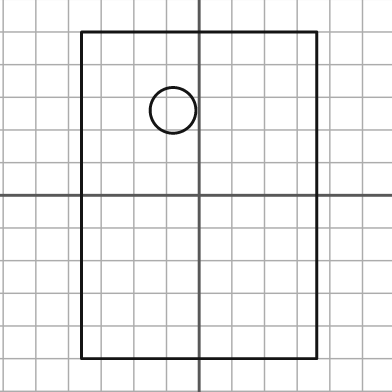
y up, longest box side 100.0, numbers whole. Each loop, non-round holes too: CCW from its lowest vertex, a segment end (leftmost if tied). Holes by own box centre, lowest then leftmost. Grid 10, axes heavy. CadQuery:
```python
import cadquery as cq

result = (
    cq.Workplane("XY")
    .moveTo(-36.0, -50.0)
    .lineTo(36.0, -50.0)
    .lineTo(36.0, 50.0)
    .lineTo(-36.0, 50.0)
    .close()
    .moveTo(-8.0, 26.0)
    .circle(7.0)
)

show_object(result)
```